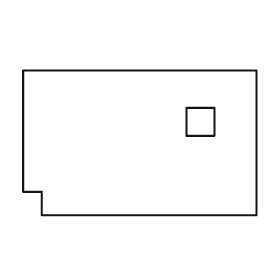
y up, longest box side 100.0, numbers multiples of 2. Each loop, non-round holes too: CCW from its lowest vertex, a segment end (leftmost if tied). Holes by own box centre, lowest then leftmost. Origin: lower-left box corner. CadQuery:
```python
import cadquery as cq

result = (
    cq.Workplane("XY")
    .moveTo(8.0, 0.0)
    .lineTo(100.0, 0.0)
    .lineTo(100.0, 62.0)
    .lineTo(0.0, 62.0)
    .lineTo(0.0, 10.0)
    .lineTo(8.0, 10.0)
    .close()
    .moveTo(70.0, 34.0)
    .lineTo(82.0, 34.0)
    .lineTo(82.0, 46.0)
    .lineTo(70.0, 46.0)
    .close()
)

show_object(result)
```